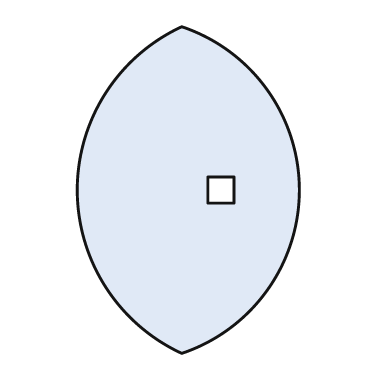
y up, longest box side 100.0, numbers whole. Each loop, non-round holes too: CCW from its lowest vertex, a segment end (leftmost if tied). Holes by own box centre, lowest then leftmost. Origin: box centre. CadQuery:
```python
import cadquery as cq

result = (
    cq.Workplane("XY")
    .moveTo(-2.0, -50.0)
    .threePointArc((34.0, 0.0), (-2.0, 50.0))
    .threePointArc((-34.0, 0.0), (-2.0, -50.0))
    .close()
    .moveTo(6.0, -4.0)
    .lineTo(14.0, -4.0)
    .lineTo(14.0, 4.0)
    .lineTo(6.0, 4.0)
    .close()
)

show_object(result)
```